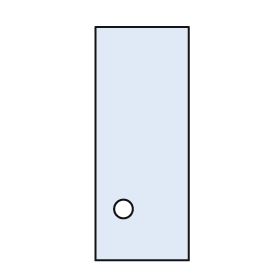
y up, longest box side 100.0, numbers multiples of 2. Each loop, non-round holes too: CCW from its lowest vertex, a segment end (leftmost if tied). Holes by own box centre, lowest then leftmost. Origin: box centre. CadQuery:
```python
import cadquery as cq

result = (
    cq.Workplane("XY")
    .moveTo(-20.0, -50.0)
    .lineTo(20.0, -50.0)
    .lineTo(20.0, 50.0)
    .lineTo(-20.0, 50.0)
    .close()
    .moveTo(-8.0, -28.0)
    .circle(4.0)
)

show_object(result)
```